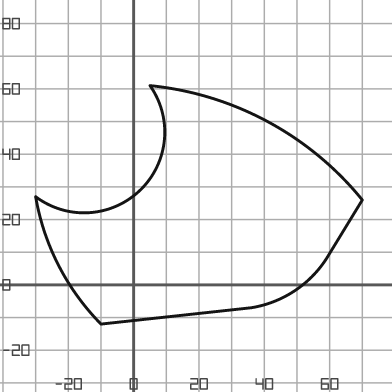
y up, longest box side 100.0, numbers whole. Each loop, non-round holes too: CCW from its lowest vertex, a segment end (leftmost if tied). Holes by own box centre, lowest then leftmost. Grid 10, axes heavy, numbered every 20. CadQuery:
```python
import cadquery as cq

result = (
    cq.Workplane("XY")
    .moveTo(-10.0, -12.0)
    .lineTo(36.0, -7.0)
    .threePointArc((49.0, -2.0), (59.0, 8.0))
    .lineTo(70.0, 26.0)
    .threePointArc((41.0, 50.0), (5.0, 61.0))
    .threePointArc((2.0, 29.0), (-30.0, 27.0))
    .threePointArc((-23.0, 6.0), (-10.0, -12.0))
    .close()
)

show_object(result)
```